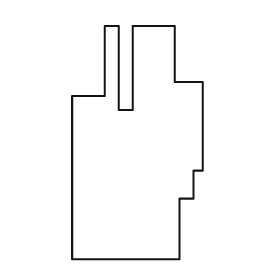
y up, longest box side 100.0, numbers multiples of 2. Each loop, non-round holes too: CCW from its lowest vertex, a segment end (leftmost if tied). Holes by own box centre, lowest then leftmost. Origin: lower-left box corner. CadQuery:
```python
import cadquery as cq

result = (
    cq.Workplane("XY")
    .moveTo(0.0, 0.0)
    .lineTo(46.0, 0.0)
    .lineTo(46.0, 26.0)
    .lineTo(52.0, 26.0)
    .lineTo(52.0, 38.0)
    .lineTo(56.0, 38.0)
    .lineTo(56.0, 76.0)
    .lineTo(44.0, 76.0)
    .lineTo(44.0, 100.0)
    .lineTo(26.0, 100.0)
    .lineTo(26.0, 64.0)
    .lineTo(20.0, 64.0)
    .lineTo(20.0, 100.0)
    .lineTo(14.0, 100.0)
    .lineTo(14.0, 70.0)
    .lineTo(0.0, 70.0)
    .close()
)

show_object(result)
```